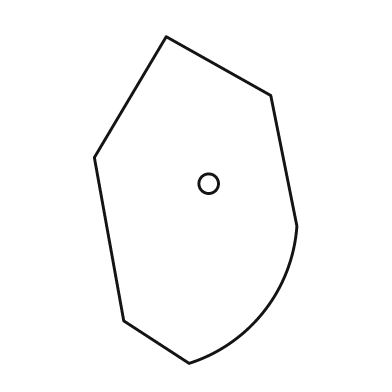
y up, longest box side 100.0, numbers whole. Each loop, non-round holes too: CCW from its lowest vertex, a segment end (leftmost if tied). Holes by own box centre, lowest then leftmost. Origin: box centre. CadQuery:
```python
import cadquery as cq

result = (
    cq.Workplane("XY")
    .moveTo(-2.0, -50.0)
    .threePointArc((21.0, -34.0), (31.0, -8.0))
    .lineTo(23.0, 32.0)
    .lineTo(-9.0, 50.0)
    .lineTo(-31.0, 13.0)
    .lineTo(-22.0, -37.0)
    .close()
    .moveTo(4.0, 5.0)
    .circle(3.0)
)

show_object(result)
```